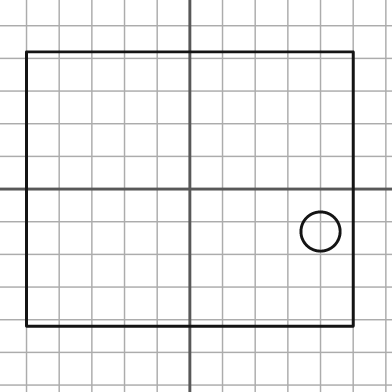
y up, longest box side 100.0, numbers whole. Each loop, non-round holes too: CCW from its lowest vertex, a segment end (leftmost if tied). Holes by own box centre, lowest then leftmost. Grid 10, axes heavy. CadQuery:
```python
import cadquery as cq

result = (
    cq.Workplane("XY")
    .moveTo(-50.0, -42.0)
    .lineTo(50.0, -42.0)
    .lineTo(50.0, 42.0)
    .lineTo(-50.0, 42.0)
    .close()
    .moveTo(40.0, -13.0)
    .circle(6.0)
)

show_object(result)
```